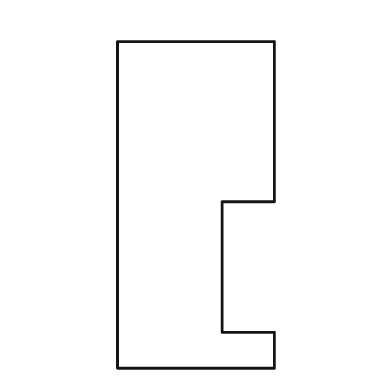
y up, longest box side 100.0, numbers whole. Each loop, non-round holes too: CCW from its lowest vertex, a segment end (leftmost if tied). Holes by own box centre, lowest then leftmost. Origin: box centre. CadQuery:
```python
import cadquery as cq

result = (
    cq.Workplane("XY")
    .moveTo(-24.0, -50.0)
    .lineTo(24.0, -50.0)
    .lineTo(24.0, -39.0)
    .lineTo(8.0, -39.0)
    .lineTo(8.0, 1.0)
    .lineTo(24.0, 1.0)
    .lineTo(24.0, 50.0)
    .lineTo(-24.0, 50.0)
    .close()
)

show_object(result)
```